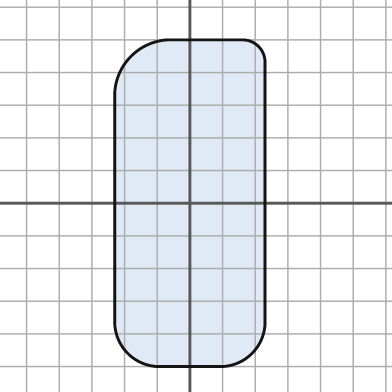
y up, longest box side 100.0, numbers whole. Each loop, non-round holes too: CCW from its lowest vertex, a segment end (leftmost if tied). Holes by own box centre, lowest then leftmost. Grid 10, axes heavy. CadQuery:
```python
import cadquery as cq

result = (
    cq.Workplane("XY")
    .moveTo(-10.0, -50.0)
    .lineTo(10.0, -50.0)
    .threePointArc((19.0, -46.0), (23.0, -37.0))
    .lineTo(23.0, 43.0)
    .threePointArc((21.0, 48.0), (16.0, 50.0))
    .lineTo(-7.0, 50.0)
    .threePointArc((-18.0, 45.0), (-23.0, 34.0))
    .lineTo(-23.0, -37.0)
    .threePointArc((-19.0, -46.0), (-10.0, -50.0))
    .close()
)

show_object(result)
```